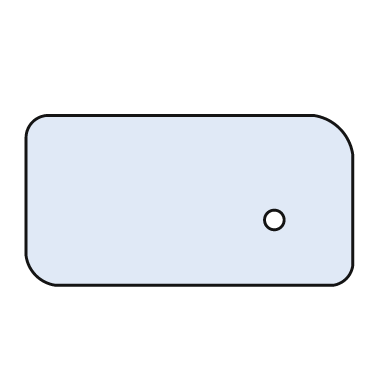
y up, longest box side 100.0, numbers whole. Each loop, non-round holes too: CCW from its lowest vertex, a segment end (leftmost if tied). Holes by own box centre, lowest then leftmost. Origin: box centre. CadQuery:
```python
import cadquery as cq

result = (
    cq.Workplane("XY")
    .moveTo(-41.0, -26.0)
    .lineTo(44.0, -26.0)
    .threePointArc((48.0, -24.0), (50.0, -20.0))
    .lineTo(50.0, 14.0)
    .threePointArc((46.0, 22.0), (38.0, 26.0))
    .lineTo(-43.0, 26.0)
    .threePointArc((-48.0, 24.0), (-50.0, 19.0))
    .lineTo(-50.0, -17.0)
    .threePointArc((-47.0, -23.0), (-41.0, -26.0))
    .close()
    .moveTo(26.0, -6.0)
    .circle(3.0)
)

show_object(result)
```